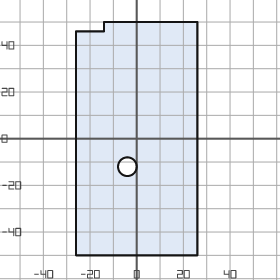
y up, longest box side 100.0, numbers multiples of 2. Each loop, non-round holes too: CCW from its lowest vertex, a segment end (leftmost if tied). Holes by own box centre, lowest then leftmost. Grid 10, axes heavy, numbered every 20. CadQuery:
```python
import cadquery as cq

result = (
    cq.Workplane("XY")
    .moveTo(-26.0, -50.0)
    .lineTo(26.0, -50.0)
    .lineTo(26.0, 50.0)
    .lineTo(-14.0, 50.0)
    .lineTo(-14.0, 46.0)
    .lineTo(-26.0, 46.0)
    .close()
    .moveTo(-4.0, -12.0)
    .circle(4.0)
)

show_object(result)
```